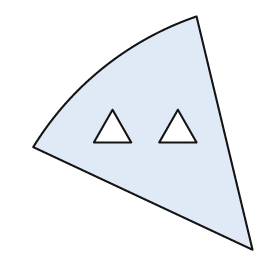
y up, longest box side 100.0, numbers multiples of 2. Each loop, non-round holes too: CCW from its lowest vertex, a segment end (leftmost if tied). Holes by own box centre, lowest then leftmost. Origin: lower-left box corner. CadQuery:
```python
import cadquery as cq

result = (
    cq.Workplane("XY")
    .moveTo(94.0, 0.0)
    .lineTo(70.0, 100.0)
    .threePointArc((30.0, 78.0), (0.0, 44.0))
    .close()
    .moveTo(26.0, 46.0)
    .lineTo(42.0, 46.0)
    .lineTo(34.0, 60.0)
    .close()
    .moveTo(54.0, 46.0)
    .lineTo(70.0, 46.0)
    .lineTo(62.0, 60.0)
    .close()
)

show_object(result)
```